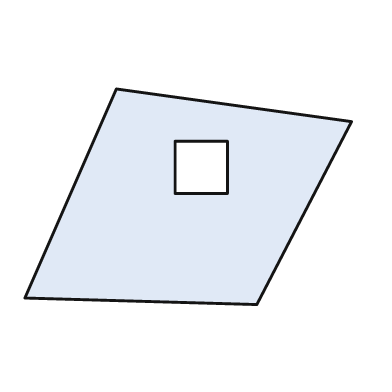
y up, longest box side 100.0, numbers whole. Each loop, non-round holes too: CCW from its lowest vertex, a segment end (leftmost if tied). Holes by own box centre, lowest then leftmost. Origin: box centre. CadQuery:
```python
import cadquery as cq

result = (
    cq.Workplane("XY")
    .moveTo(21.0, -33.0)
    .lineTo(50.0, 23.0)
    .lineTo(-22.0, 33.0)
    .lineTo(-50.0, -31.0)
    .close()
    .moveTo(-4.0, 1.0)
    .lineTo(12.0, 1.0)
    .lineTo(12.0, 17.0)
    .lineTo(-4.0, 17.0)
    .close()
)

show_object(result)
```